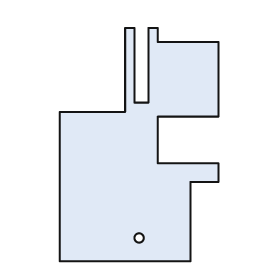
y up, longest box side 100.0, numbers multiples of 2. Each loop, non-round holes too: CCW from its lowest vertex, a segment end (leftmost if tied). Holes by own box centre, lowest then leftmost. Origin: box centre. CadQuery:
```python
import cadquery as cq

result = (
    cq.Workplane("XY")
    .moveTo(-34.0, -50.0)
    .lineTo(22.0, -50.0)
    .lineTo(22.0, -16.0)
    .lineTo(34.0, -16.0)
    .lineTo(34.0, -8.0)
    .lineTo(8.0, -8.0)
    .lineTo(8.0, 12.0)
    .lineTo(34.0, 12.0)
    .lineTo(34.0, 44.0)
    .lineTo(8.0, 44.0)
    .lineTo(8.0, 50.0)
    .lineTo(4.0, 50.0)
    .lineTo(4.0, 18.0)
    .lineTo(-2.0, 18.0)
    .lineTo(-2.0, 50.0)
    .lineTo(-6.0, 50.0)
    .lineTo(-6.0, 14.0)
    .lineTo(-34.0, 14.0)
    .close()
    .moveTo(0.0, -40.0)
    .circle(2.0)
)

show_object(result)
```